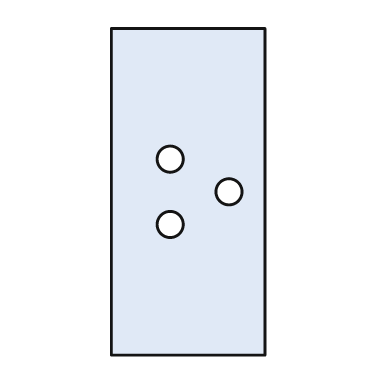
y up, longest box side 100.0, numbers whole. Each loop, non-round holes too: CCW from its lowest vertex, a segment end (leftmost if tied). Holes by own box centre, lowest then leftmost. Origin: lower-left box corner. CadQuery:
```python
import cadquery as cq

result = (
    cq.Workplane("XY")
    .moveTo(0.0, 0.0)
    .lineTo(47.0, 0.0)
    .lineTo(47.0, 100.0)
    .lineTo(0.0, 100.0)
    .close()
    .moveTo(18.0, 40.0)
    .circle(4.0)
    .moveTo(36.0, 50.0)
    .circle(4.0)
    .moveTo(18.0, 60.0)
    .circle(4.0)
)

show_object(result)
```